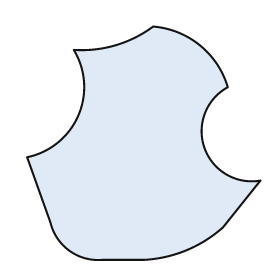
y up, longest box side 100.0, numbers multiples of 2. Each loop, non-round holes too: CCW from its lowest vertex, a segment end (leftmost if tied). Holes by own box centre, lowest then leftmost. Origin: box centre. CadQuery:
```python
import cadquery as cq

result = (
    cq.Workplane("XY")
    .moveTo(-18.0, -50.0)
    .lineTo(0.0, -50.0)
    .threePointArc((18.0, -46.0), (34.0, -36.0))
    .lineTo(50.0, -16.0)
    .threePointArc((26.0, -2.0), (36.0, 24.0))
    .threePointArc((24.0, 42.0), (4.0, 50.0))
    .threePointArc((-12.0, 42.0), (-30.0, 40.0))
    .threePointArc((-28.0, 12.0), (-50.0, -6.0))
    .lineTo(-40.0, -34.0)
    .threePointArc((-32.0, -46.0), (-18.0, -50.0))
    .close()
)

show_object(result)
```